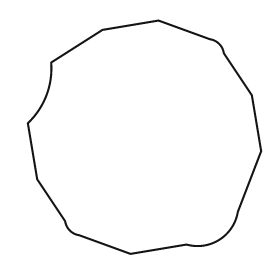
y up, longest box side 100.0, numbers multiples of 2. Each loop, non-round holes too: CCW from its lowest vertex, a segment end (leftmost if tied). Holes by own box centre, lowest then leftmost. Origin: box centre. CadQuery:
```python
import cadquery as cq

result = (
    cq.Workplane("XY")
    .moveTo(-6.0, -50.0)
    .lineTo(18.0, -46.0)
    .threePointArc((32.0, -44.0), (40.0, -32.0))
    .lineTo(50.0, -6.0)
    .lineTo(46.0, 18.0)
    .lineTo(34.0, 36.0)
    .threePointArc((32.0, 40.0), (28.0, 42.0))
    .lineTo(6.0, 50.0)
    .lineTo(-18.0, 46.0)
    .lineTo(-40.0, 32.0)
    .threePointArc((-42.0, 18.0), (-50.0, 6.0))
    .lineTo(-46.0, -18.0)
    .lineTo(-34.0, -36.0)
    .threePointArc((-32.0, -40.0), (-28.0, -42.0))
    .close()
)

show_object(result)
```